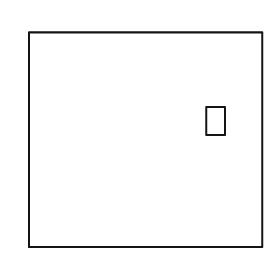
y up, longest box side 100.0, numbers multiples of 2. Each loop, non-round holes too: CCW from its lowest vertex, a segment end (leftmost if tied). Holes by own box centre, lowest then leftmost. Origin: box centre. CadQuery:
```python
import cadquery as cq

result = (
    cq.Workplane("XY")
    .moveTo(-50.0, -46.0)
    .lineTo(50.0, -46.0)
    .lineTo(50.0, 46.0)
    .lineTo(-50.0, 46.0)
    .close()
    .moveTo(26.0, 2.0)
    .lineTo(34.0, 2.0)
    .lineTo(34.0, 14.0)
    .lineTo(26.0, 14.0)
    .close()
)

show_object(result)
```